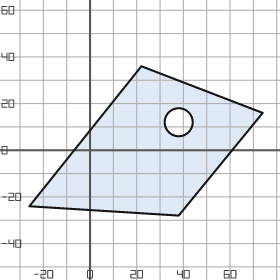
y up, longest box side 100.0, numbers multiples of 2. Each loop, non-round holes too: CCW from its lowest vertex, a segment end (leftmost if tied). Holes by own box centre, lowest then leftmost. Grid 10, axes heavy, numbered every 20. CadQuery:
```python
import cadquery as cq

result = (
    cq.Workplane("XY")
    .moveTo(38.0, -28.0)
    .lineTo(74.0, 16.0)
    .lineTo(22.0, 36.0)
    .lineTo(-26.0, -24.0)
    .close()
    .moveTo(38.0, 12.0)
    .circle(6.0)
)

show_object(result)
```